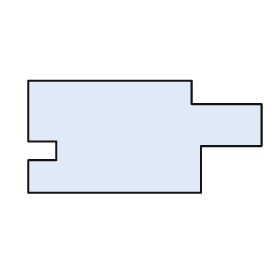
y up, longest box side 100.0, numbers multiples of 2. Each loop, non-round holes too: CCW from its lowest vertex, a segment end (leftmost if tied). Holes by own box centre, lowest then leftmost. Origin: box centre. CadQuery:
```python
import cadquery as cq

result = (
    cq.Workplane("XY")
    .moveTo(-50.0, -24.0)
    .lineTo(24.0, -24.0)
    .lineTo(24.0, -4.0)
    .lineTo(50.0, -4.0)
    .lineTo(50.0, 14.0)
    .lineTo(20.0, 14.0)
    .lineTo(20.0, 24.0)
    .lineTo(-50.0, 24.0)
    .lineTo(-50.0, -2.0)
    .lineTo(-38.0, -2.0)
    .lineTo(-38.0, -10.0)
    .lineTo(-50.0, -10.0)
    .close()
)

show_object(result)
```